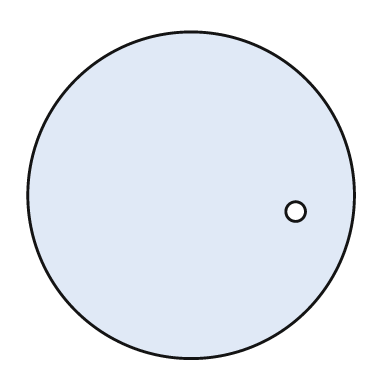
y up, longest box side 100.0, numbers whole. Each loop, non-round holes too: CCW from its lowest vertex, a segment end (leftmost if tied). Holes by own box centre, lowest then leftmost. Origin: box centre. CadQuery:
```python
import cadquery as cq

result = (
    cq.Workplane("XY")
    .moveTo(0.0, 0.0)
    .circle(50.0)
    .moveTo(32.0, -5.0)
    .circle(3.0)
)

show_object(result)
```